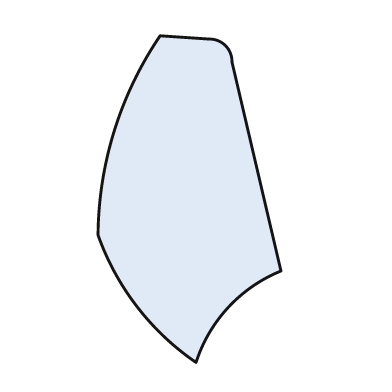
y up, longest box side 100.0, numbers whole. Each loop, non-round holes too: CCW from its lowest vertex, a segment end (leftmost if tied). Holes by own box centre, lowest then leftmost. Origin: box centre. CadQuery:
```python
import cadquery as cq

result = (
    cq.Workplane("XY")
    .moveTo(2.0, -50.0)
    .threePointArc((12.0, -33.0), (28.0, -22.0))
    .lineTo(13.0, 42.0)
    .threePointArc((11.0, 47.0), (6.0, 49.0))
    .lineTo(-9.0, 50.0)
    .threePointArc((-23.0, 21.0), (-28.0, -11.0))
    .threePointArc((-16.0, -33.0), (2.0, -50.0))
    .close()
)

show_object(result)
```